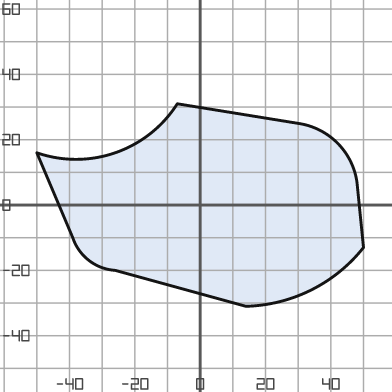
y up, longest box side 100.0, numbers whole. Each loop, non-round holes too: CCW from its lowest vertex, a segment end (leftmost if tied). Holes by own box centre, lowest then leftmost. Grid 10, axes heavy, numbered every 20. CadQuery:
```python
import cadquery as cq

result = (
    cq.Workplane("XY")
    .moveTo(14.0, -31.0)
    .threePointArc((34.0, -26.0), (50.0, -13.0))
    .lineTo(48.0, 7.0)
    .threePointArc((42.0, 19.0), (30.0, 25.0))
    .lineTo(-7.0, 31.0)
    .threePointArc((-26.0, 16.0), (-50.0, 16.0))
    .lineTo(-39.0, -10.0)
    .threePointArc((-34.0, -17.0), (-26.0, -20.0))
    .close()
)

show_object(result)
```